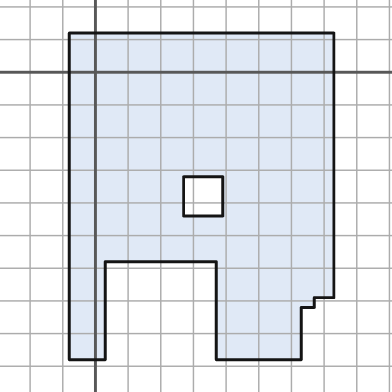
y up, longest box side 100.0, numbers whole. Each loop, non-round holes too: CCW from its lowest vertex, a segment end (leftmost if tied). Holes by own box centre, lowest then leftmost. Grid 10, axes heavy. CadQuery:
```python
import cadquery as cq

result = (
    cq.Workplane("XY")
    .moveTo(-8.0, -88.0)
    .lineTo(3.0, -88.0)
    .lineTo(3.0, -58.0)
    .lineTo(37.0, -58.0)
    .lineTo(37.0, -88.0)
    .lineTo(63.0, -88.0)
    .lineTo(63.0, -72.0)
    .lineTo(67.0, -72.0)
    .lineTo(67.0, -69.0)
    .lineTo(73.0, -69.0)
    .lineTo(73.0, 12.0)
    .lineTo(-8.0, 12.0)
    .close()
    .moveTo(27.0, -44.0)
    .lineTo(39.0, -44.0)
    .lineTo(39.0, -32.0)
    .lineTo(27.0, -32.0)
    .close()
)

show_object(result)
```